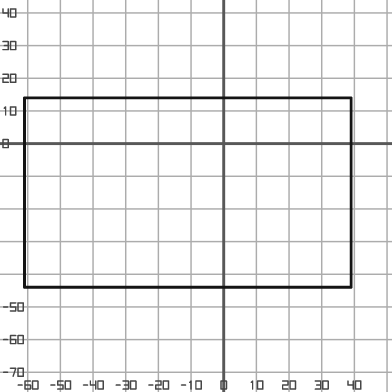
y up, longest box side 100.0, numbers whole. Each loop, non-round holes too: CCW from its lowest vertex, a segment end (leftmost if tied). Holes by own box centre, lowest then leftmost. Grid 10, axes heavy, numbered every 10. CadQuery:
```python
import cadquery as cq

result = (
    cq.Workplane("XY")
    .moveTo(-61.0, -44.0)
    .lineTo(39.0, -44.0)
    .lineTo(39.0, 14.0)
    .lineTo(-61.0, 14.0)
    .close()
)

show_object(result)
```